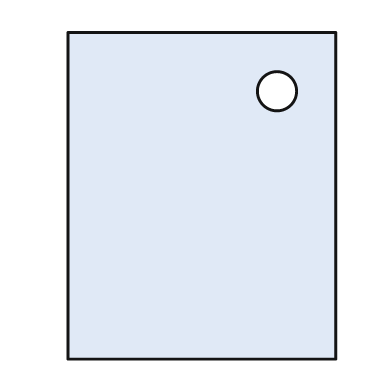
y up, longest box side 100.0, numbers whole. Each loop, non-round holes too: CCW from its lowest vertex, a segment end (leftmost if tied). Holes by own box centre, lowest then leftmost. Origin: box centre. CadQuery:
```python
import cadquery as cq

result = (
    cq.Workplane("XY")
    .moveTo(-41.0, -50.0)
    .lineTo(41.0, -50.0)
    .lineTo(41.0, 50.0)
    .lineTo(-41.0, 50.0)
    .close()
    .moveTo(23.0, 32.0)
    .circle(6.0)
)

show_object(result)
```